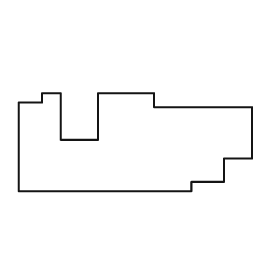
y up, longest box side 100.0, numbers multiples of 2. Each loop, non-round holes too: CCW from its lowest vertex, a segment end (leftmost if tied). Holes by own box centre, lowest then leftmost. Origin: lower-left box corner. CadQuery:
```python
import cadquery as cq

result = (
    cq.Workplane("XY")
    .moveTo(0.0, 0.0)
    .lineTo(74.0, 0.0)
    .lineTo(74.0, 4.0)
    .lineTo(88.0, 4.0)
    .lineTo(88.0, 14.0)
    .lineTo(100.0, 14.0)
    .lineTo(100.0, 36.0)
    .lineTo(58.0, 36.0)
    .lineTo(58.0, 42.0)
    .lineTo(34.0, 42.0)
    .lineTo(34.0, 22.0)
    .lineTo(18.0, 22.0)
    .lineTo(18.0, 42.0)
    .lineTo(10.0, 42.0)
    .lineTo(10.0, 38.0)
    .lineTo(0.0, 38.0)
    .close()
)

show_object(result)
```